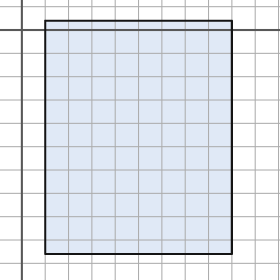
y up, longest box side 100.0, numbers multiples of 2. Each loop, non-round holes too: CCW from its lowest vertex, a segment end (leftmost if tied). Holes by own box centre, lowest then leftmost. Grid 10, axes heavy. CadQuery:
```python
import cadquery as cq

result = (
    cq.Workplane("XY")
    .moveTo(10.0, -96.0)
    .lineTo(90.0, -96.0)
    .lineTo(90.0, 4.0)
    .lineTo(10.0, 4.0)
    .close()
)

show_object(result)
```